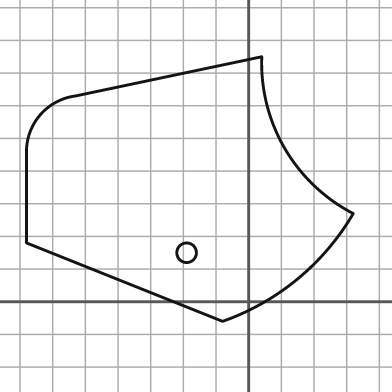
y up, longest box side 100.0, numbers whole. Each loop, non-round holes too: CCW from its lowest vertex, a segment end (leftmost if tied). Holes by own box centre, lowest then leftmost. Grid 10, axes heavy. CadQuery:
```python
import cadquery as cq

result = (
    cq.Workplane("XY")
    .moveTo(-8.0, -6.0)
    .threePointArc((15.0, 7.0), (32.0, 27.0))
    .threePointArc((11.0, 47.0), (4.0, 75.0))
    .lineTo(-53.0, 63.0)
    .threePointArc((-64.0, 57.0), (-68.0, 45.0))
    .lineTo(-68.0, 18.0)
    .close()
    .moveTo(-19.0, 15.0)
    .circle(3.0)
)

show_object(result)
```